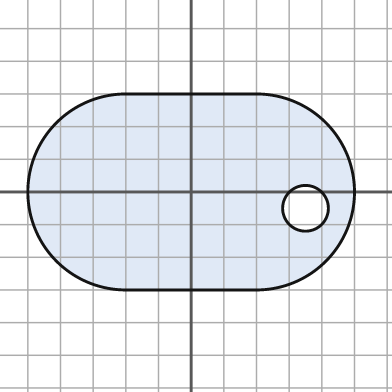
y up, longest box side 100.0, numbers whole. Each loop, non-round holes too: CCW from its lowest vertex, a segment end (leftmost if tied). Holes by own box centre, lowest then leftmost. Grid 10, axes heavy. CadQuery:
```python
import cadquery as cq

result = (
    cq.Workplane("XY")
    .moveTo(-20.0, -30.0)
    .lineTo(20.0, -30.0)
    .threePointArc((50.0, 0.0), (20.0, 30.0))
    .lineTo(-20.0, 30.0)
    .threePointArc((-50.0, 0.0), (-20.0, -30.0))
    .close()
    .moveTo(35.0, -5.0)
    .circle(7.0)
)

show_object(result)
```